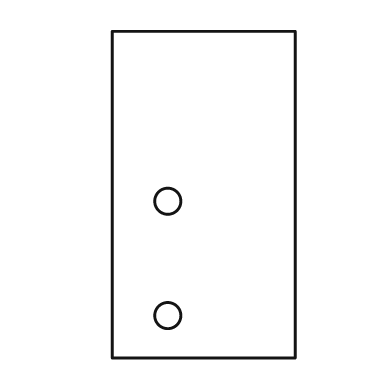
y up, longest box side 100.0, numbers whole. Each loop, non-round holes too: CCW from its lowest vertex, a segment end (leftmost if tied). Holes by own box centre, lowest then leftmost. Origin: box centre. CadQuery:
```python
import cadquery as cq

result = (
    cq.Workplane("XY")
    .moveTo(-28.0, -50.0)
    .lineTo(28.0, -50.0)
    .lineTo(28.0, 50.0)
    .lineTo(-28.0, 50.0)
    .close()
    .moveTo(-11.0, -37.0)
    .circle(4.0)
    .moveTo(-11.0, -2.0)
    .circle(4.0)
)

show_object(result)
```